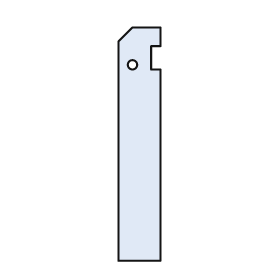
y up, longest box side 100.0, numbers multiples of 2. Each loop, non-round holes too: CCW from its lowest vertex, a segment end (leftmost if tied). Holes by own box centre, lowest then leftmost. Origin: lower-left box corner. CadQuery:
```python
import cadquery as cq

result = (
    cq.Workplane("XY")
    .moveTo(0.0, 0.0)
    .lineTo(18.0, 0.0)
    .lineTo(18.0, 82.0)
    .lineTo(14.0, 82.0)
    .lineTo(14.0, 92.0)
    .lineTo(18.0, 92.0)
    .lineTo(18.0, 100.0)
    .lineTo(6.0, 100.0)
    .lineTo(0.0, 94.0)
    .close()
    .moveTo(6.0, 84.0)
    .circle(2.0)
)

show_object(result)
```